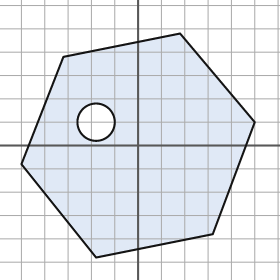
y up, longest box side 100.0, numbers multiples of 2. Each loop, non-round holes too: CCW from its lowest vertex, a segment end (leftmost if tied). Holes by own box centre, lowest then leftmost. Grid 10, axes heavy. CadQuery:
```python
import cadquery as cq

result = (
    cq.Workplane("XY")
    .moveTo(-18.0, -48.0)
    .lineTo(32.0, -38.0)
    .lineTo(50.0, 10.0)
    .lineTo(18.0, 48.0)
    .lineTo(-32.0, 38.0)
    .lineTo(-50.0, -8.0)
    .close()
    .moveTo(-18.0, 10.0)
    .circle(8.0)
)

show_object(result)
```